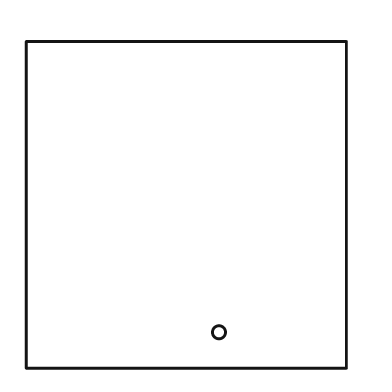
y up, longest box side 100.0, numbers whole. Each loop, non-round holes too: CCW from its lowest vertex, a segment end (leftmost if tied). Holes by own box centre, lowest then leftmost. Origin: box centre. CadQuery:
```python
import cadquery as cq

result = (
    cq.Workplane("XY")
    .moveTo(-49.0, -50.0)
    .lineTo(49.0, -50.0)
    .lineTo(49.0, 50.0)
    .lineTo(-49.0, 50.0)
    .close()
    .moveTo(10.0, -39.0)
    .circle(2.0)
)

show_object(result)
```